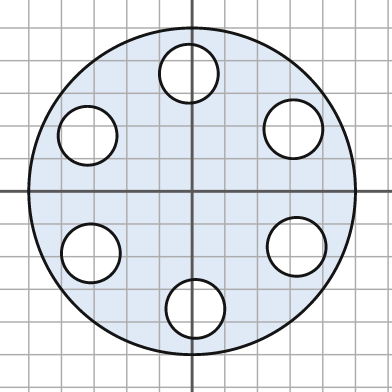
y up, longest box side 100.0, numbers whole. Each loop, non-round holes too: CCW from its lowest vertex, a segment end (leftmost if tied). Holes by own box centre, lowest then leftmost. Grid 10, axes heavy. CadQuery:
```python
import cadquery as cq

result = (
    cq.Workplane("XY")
    .moveTo(0.0, 0.0)
    .circle(50.0)
    .moveTo(1.0, -36.0)
    .circle(9.0)
    .moveTo(-31.0, -19.0)
    .circle(9.0)
    .moveTo(32.0, -17.0)
    .circle(9.0)
    .moveTo(-32.0, 17.0)
    .circle(9.0)
    .moveTo(31.0, 19.0)
    .circle(9.0)
    .moveTo(-1.0, 36.0)
    .circle(9.0)
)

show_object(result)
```